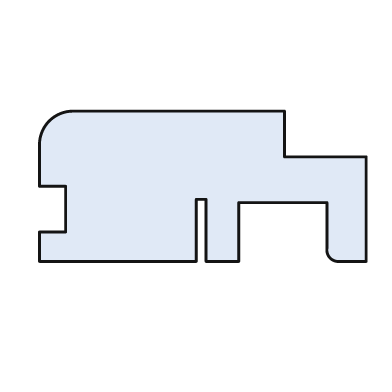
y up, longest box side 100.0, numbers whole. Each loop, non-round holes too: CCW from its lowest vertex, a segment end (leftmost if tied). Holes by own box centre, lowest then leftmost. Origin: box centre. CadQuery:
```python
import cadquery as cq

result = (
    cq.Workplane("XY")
    .moveTo(-50.0, -23.0)
    .lineTo(-2.0, -23.0)
    .lineTo(-2.0, -4.0)
    .lineTo(1.0, -4.0)
    .lineTo(1.0, -23.0)
    .lineTo(11.0, -23.0)
    .lineTo(11.0, -5.0)
    .lineTo(38.0, -5.0)
    .lineTo(38.0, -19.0)
    .threePointArc((39.0, -22.0), (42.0, -23.0))
    .lineTo(50.0, -23.0)
    .lineTo(50.0, 9.0)
    .lineTo(25.0, 9.0)
    .lineTo(25.0, 23.0)
    .lineTo(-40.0, 23.0)
    .threePointArc((-47.0, 20.0), (-50.0, 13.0))
    .lineTo(-50.0, 0.0)
    .lineTo(-42.0, 0.0)
    .lineTo(-42.0, -14.0)
    .lineTo(-50.0, -14.0)
    .close()
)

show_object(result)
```